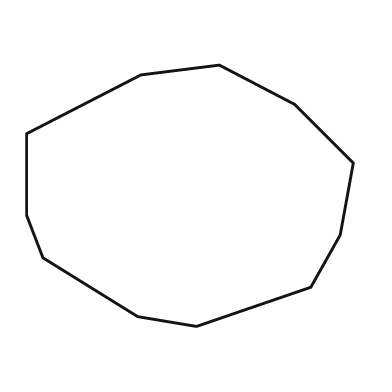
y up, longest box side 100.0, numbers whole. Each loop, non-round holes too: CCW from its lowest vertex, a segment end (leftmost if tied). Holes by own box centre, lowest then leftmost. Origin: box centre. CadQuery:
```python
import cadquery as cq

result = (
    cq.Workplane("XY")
    .moveTo(2.0, -40.0)
    .lineTo(37.0, -28.0)
    .lineTo(46.0, -12.0)
    .lineTo(50.0, 10.0)
    .lineTo(32.0, 28.0)
    .lineTo(9.0, 40.0)
    .lineTo(-15.0, 37.0)
    .lineTo(-50.0, 19.0)
    .lineTo(-50.0, -6.0)
    .lineTo(-45.0, -19.0)
    .lineTo(-16.0, -37.0)
    .close()
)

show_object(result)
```